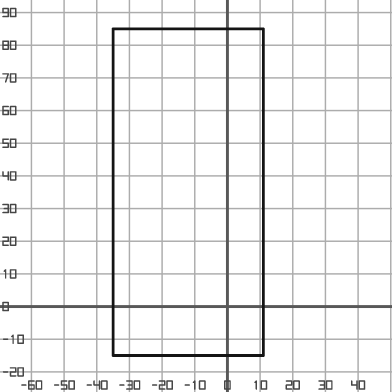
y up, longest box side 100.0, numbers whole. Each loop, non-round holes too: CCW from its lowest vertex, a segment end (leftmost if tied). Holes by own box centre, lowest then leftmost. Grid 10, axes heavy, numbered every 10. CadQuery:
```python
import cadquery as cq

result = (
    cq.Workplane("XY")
    .moveTo(-35.0, -15.0)
    .lineTo(11.0, -15.0)
    .lineTo(11.0, 85.0)
    .lineTo(-35.0, 85.0)
    .close()
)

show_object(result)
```